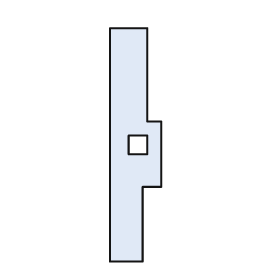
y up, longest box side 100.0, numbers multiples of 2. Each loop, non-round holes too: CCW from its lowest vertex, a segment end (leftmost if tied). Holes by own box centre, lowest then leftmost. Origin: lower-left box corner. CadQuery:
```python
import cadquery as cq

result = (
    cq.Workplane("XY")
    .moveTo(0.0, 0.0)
    .lineTo(14.0, 0.0)
    .lineTo(14.0, 32.0)
    .lineTo(22.0, 32.0)
    .lineTo(22.0, 60.0)
    .lineTo(16.0, 60.0)
    .lineTo(16.0, 100.0)
    .lineTo(0.0, 100.0)
    .close()
    .moveTo(8.0, 46.0)
    .lineTo(16.0, 46.0)
    .lineTo(16.0, 54.0)
    .lineTo(8.0, 54.0)
    .close()
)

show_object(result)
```